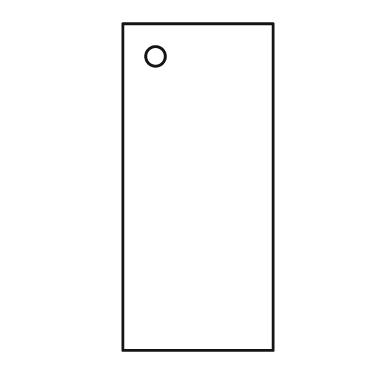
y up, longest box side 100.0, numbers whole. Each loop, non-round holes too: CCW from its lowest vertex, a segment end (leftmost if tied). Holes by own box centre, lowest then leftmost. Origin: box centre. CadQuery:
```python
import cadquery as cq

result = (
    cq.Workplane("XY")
    .moveTo(-23.0, -50.0)
    .lineTo(23.0, -50.0)
    .lineTo(23.0, 50.0)
    .lineTo(-23.0, 50.0)
    .close()
    .moveTo(-13.0, 40.0)
    .circle(3.0)
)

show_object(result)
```